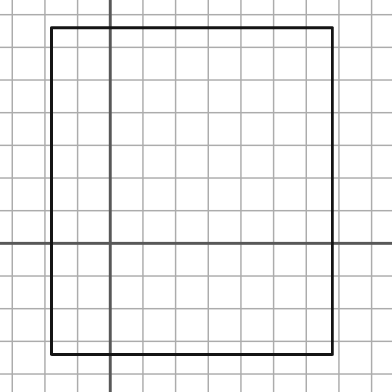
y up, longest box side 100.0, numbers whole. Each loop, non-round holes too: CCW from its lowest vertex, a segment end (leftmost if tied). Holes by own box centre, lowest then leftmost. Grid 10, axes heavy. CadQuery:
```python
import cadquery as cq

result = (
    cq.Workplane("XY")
    .moveTo(-18.0, -34.0)
    .lineTo(68.0, -34.0)
    .lineTo(68.0, 66.0)
    .lineTo(-18.0, 66.0)
    .close()
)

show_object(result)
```